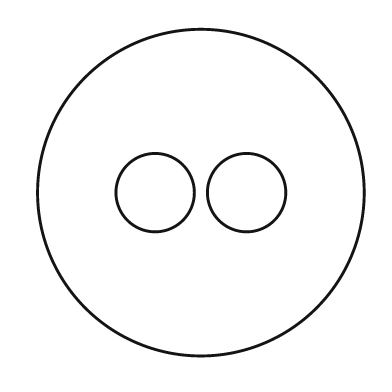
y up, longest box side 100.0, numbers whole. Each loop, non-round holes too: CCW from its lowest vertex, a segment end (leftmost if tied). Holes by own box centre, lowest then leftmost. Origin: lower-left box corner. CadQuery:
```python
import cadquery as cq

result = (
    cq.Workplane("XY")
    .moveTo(50.0, 50.0)
    .circle(50.0)
    .moveTo(36.0, 50.0)
    .circle(12.0)
    .moveTo(64.0, 50.0)
    .circle(12.0)
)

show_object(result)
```